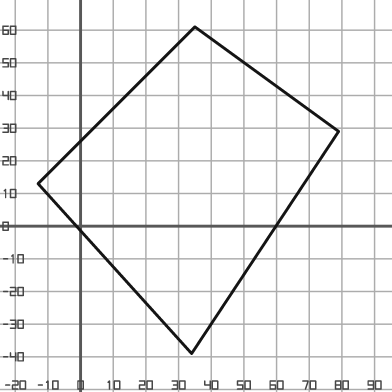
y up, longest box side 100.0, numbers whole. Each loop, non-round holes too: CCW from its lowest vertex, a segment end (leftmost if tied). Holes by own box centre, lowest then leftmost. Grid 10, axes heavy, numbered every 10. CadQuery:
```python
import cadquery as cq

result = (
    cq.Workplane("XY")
    .moveTo(34.0, -39.0)
    .lineTo(79.0, 29.0)
    .lineTo(35.0, 61.0)
    .lineTo(-13.0, 13.0)
    .close()
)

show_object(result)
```